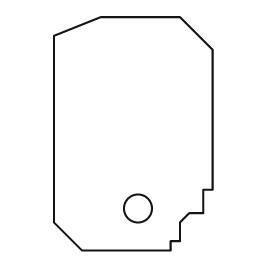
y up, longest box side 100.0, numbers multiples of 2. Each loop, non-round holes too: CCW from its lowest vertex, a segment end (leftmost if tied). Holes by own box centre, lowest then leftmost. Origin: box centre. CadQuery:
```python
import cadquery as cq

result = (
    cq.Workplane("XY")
    .moveTo(-22.0, -50.0)
    .lineTo(16.0, -50.0)
    .lineTo(16.0, -46.0)
    .lineTo(20.0, -46.0)
    .lineTo(20.0, -38.0)
    .lineTo(24.0, -34.0)
    .lineTo(30.0, -34.0)
    .lineTo(30.0, -24.0)
    .lineTo(34.0, -24.0)
    .lineTo(34.0, 36.0)
    .lineTo(20.0, 50.0)
    .lineTo(-14.0, 50.0)
    .lineTo(-34.0, 42.0)
    .lineTo(-34.0, -38.0)
    .close()
    .moveTo(2.0, -32.0)
    .circle(6.0)
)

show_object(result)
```